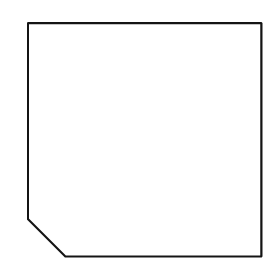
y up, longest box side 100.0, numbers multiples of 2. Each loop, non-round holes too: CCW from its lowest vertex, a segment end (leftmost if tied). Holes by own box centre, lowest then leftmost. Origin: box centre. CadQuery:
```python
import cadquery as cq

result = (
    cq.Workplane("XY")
    .moveTo(-34.0, -50.0)
    .lineTo(50.0, -50.0)
    .lineTo(50.0, 50.0)
    .lineTo(-50.0, 50.0)
    .lineTo(-50.0, -34.0)
    .close()
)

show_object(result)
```